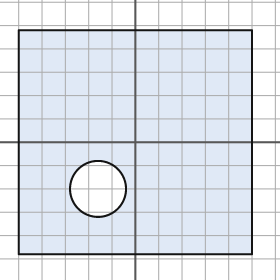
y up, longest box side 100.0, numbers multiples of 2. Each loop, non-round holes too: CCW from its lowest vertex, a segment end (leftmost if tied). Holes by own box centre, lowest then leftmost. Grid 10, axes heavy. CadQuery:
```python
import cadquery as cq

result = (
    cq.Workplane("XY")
    .moveTo(-50.0, -48.0)
    .lineTo(50.0, -48.0)
    .lineTo(50.0, 48.0)
    .lineTo(-50.0, 48.0)
    .close()
    .moveTo(-16.0, -20.0)
    .circle(12.0)
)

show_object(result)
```